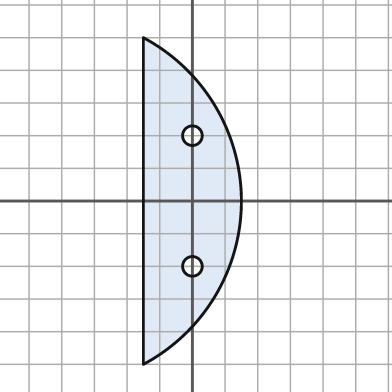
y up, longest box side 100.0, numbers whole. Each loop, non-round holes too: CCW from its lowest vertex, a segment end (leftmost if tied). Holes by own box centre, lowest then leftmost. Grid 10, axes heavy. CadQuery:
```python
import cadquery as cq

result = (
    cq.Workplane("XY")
    .moveTo(-15.0, -50.0)
    .threePointArc((15.0, 0.0), (-15.0, 50.0))
    .close()
    .moveTo(0.0, -20.0)
    .circle(3.0)
    .moveTo(0.0, 20.0)
    .circle(3.0)
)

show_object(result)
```